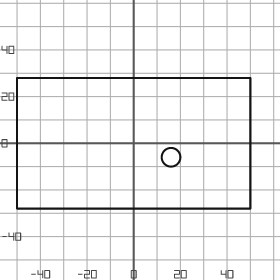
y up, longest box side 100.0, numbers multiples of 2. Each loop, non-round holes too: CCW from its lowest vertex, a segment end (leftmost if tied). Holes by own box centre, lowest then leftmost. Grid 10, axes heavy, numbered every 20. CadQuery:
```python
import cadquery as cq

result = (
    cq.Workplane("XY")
    .moveTo(-50.0, -28.0)
    .lineTo(50.0, -28.0)
    .lineTo(50.0, 28.0)
    .lineTo(-50.0, 28.0)
    .close()
    .moveTo(16.0, -6.0)
    .circle(4.0)
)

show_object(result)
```